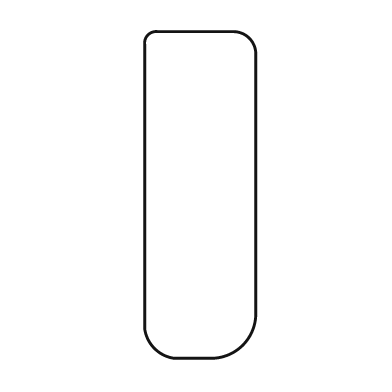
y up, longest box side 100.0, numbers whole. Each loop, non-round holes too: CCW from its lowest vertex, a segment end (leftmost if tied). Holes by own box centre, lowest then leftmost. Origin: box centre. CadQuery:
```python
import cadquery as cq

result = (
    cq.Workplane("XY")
    .moveTo(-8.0, -50.0)
    .lineTo(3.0, -50.0)
    .threePointArc((13.0, -46.0), (17.0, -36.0))
    .lineTo(17.0, 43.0)
    .threePointArc((15.0, 48.0), (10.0, 50.0))
    .lineTo(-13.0, 50.0)
    .threePointArc((-16.0, 49.0), (-17.0, 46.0))
    .lineTo(-17.0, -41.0)
    .threePointArc((-14.0, -47.0), (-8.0, -50.0))
    .close()
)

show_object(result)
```